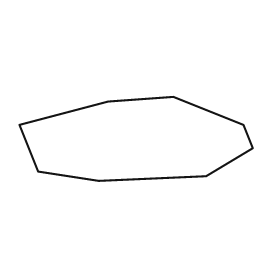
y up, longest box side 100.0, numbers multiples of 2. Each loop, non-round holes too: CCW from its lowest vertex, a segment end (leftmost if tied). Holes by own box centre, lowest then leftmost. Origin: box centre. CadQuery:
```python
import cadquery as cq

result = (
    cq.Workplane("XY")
    .moveTo(-16.0, -18.0)
    .lineTo(30.0, -16.0)
    .lineTo(50.0, -4.0)
    .lineTo(46.0, 6.0)
    .lineTo(16.0, 18.0)
    .lineTo(-12.0, 16.0)
    .lineTo(-50.0, 6.0)
    .lineTo(-42.0, -14.0)
    .close()
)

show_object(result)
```